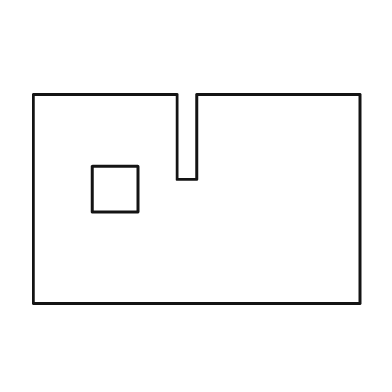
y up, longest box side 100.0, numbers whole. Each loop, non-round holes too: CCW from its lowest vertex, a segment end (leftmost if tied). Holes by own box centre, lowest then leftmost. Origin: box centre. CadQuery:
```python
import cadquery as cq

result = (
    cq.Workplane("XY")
    .moveTo(-50.0, -32.0)
    .lineTo(50.0, -32.0)
    .lineTo(50.0, 32.0)
    .lineTo(0.0, 32.0)
    .lineTo(0.0, 6.0)
    .lineTo(-6.0, 6.0)
    .lineTo(-6.0, 32.0)
    .lineTo(-50.0, 32.0)
    .close()
    .moveTo(-32.0, -4.0)
    .lineTo(-18.0, -4.0)
    .lineTo(-18.0, 10.0)
    .lineTo(-32.0, 10.0)
    .close()
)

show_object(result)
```